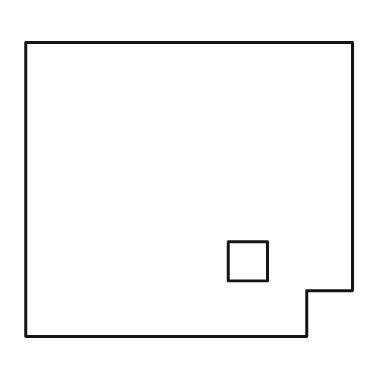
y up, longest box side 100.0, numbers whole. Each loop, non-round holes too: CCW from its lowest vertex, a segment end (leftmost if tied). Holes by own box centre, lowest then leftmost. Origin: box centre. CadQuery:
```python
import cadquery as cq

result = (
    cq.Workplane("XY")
    .moveTo(-50.0, -45.0)
    .lineTo(36.0, -45.0)
    .lineTo(36.0, -31.0)
    .lineTo(50.0, -31.0)
    .lineTo(50.0, 45.0)
    .lineTo(-50.0, 45.0)
    .close()
    .moveTo(12.0, -28.0)
    .lineTo(24.0, -28.0)
    .lineTo(24.0, -16.0)
    .lineTo(12.0, -16.0)
    .close()
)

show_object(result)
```